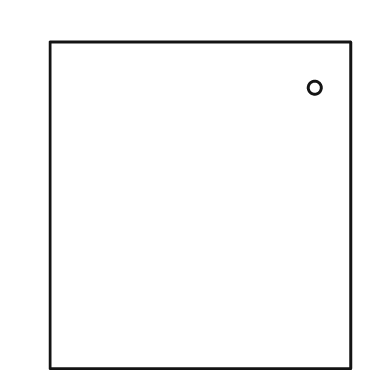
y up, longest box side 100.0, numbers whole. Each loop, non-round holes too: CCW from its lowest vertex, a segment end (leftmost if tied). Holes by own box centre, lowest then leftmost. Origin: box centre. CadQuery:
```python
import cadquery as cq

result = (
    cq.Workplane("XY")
    .moveTo(-46.0, -50.0)
    .lineTo(46.0, -50.0)
    .lineTo(46.0, 50.0)
    .lineTo(-46.0, 50.0)
    .close()
    .moveTo(35.0, 36.0)
    .circle(2.0)
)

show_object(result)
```